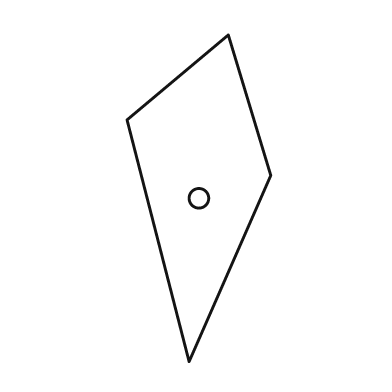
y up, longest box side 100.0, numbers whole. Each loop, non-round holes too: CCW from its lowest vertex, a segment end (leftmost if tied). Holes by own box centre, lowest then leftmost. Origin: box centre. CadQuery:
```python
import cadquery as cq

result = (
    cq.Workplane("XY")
    .moveTo(-3.0, -50.0)
    .lineTo(22.0, 7.0)
    .lineTo(9.0, 50.0)
    .lineTo(-22.0, 24.0)
    .close()
    .moveTo(0.0, 0.0)
    .circle(3.0)
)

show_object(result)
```